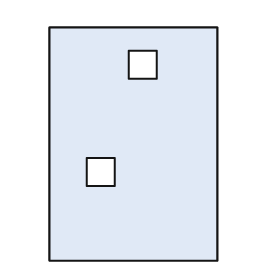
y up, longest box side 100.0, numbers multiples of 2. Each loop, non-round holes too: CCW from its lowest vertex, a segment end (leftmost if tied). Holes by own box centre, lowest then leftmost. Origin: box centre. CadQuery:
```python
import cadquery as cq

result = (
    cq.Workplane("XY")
    .moveTo(-36.0, -50.0)
    .lineTo(36.0, -50.0)
    .lineTo(36.0, 50.0)
    .lineTo(-36.0, 50.0)
    .close()
    .moveTo(-20.0, -18.0)
    .lineTo(-8.0, -18.0)
    .lineTo(-8.0, -6.0)
    .lineTo(-20.0, -6.0)
    .close()
    .moveTo(-2.0, 28.0)
    .lineTo(10.0, 28.0)
    .lineTo(10.0, 40.0)
    .lineTo(-2.0, 40.0)
    .close()
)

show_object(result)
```